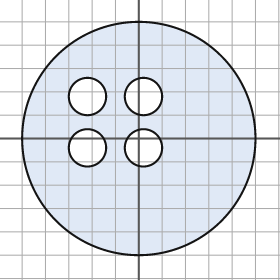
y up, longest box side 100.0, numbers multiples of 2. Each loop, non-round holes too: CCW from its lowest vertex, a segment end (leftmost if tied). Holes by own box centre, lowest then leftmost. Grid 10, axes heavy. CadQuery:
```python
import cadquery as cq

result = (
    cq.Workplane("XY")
    .moveTo(0.0, 0.0)
    .circle(50.0)
    .moveTo(-22.0, -4.0)
    .circle(8.0)
    .moveTo(2.0, -4.0)
    .circle(8.0)
    .moveTo(-22.0, 18.0)
    .circle(8.0)
    .moveTo(2.0, 18.0)
    .circle(8.0)
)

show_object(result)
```